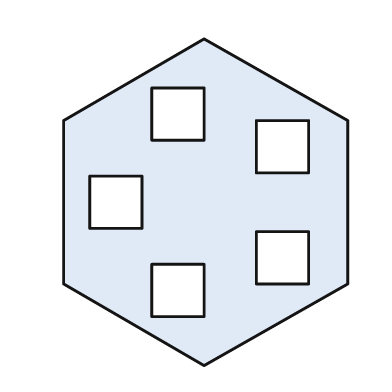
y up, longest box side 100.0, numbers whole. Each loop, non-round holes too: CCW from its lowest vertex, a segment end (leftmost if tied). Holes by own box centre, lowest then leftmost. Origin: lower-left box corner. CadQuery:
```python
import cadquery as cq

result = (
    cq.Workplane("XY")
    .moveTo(43.0, 0.0)
    .lineTo(87.0, 25.0)
    .lineTo(87.0, 75.0)
    .lineTo(43.0, 100.0)
    .lineTo(0.0, 75.0)
    .lineTo(0.0, 25.0)
    .close()
    .moveTo(27.0, 15.0)
    .lineTo(43.0, 15.0)
    .lineTo(43.0, 31.0)
    .lineTo(27.0, 31.0)
    .close()
    .moveTo(59.0, 25.0)
    .lineTo(75.0, 25.0)
    .lineTo(75.0, 41.0)
    .lineTo(59.0, 41.0)
    .close()
    .moveTo(8.0, 42.0)
    .lineTo(24.0, 42.0)
    .lineTo(24.0, 58.0)
    .lineTo(8.0, 58.0)
    .close()
    .moveTo(59.0, 59.0)
    .lineTo(75.0, 59.0)
    .lineTo(75.0, 75.0)
    .lineTo(59.0, 75.0)
    .close()
    .moveTo(27.0, 69.0)
    .lineTo(43.0, 69.0)
    .lineTo(43.0, 85.0)
    .lineTo(27.0, 85.0)
    .close()
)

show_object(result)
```